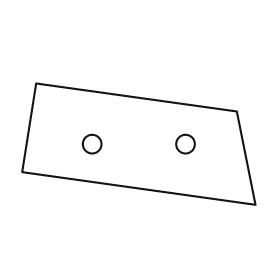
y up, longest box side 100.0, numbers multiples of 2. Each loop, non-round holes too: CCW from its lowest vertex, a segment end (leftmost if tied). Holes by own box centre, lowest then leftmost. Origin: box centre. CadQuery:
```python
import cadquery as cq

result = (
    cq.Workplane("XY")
    .moveTo(50.0, -26.0)
    .lineTo(42.0, 14.0)
    .lineTo(-44.0, 26.0)
    .lineTo(-50.0, -12.0)
    .close()
    .moveTo(-20.0, 0.0)
    .circle(4.0)
    .moveTo(20.0, 0.0)
    .circle(4.0)
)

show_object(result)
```